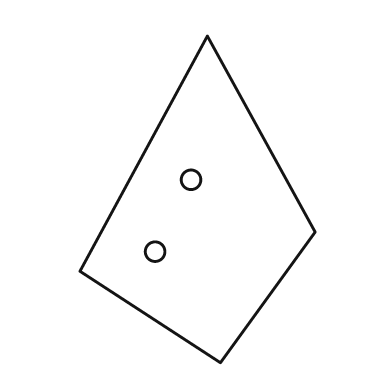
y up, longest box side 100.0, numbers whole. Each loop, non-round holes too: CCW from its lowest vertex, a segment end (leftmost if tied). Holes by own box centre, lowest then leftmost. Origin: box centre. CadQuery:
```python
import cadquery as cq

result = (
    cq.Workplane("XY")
    .moveTo(7.0, -50.0)
    .lineTo(36.0, -10.0)
    .lineTo(3.0, 50.0)
    .lineTo(-36.0, -22.0)
    .close()
    .moveTo(-13.0, -16.0)
    .circle(3.0)
    .moveTo(-2.0, 6.0)
    .circle(3.0)
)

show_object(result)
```